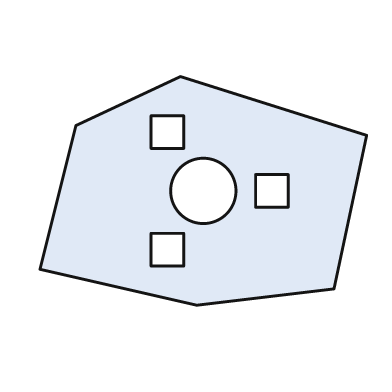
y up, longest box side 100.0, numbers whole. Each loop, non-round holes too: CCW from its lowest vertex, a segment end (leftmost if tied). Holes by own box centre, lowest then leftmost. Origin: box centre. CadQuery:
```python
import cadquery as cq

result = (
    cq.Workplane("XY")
    .moveTo(-2.0, -35.0)
    .lineTo(40.0, -30.0)
    .lineTo(50.0, 17.0)
    .lineTo(-7.0, 35.0)
    .lineTo(-39.0, 20.0)
    .lineTo(-50.0, -24.0)
    .close()
    .moveTo(-16.0, -23.0)
    .lineTo(-6.0, -23.0)
    .lineTo(-6.0, -13.0)
    .lineTo(-16.0, -13.0)
    .close()
    .moveTo(0.0, 0.0)
    .circle(10.0)
    .moveTo(16.0, -5.0)
    .lineTo(26.0, -5.0)
    .lineTo(26.0, 5.0)
    .lineTo(16.0, 5.0)
    .close()
    .moveTo(-16.0, 13.0)
    .lineTo(-6.0, 13.0)
    .lineTo(-6.0, 23.0)
    .lineTo(-16.0, 23.0)
    .close()
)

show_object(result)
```